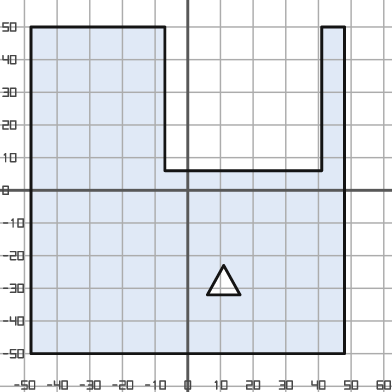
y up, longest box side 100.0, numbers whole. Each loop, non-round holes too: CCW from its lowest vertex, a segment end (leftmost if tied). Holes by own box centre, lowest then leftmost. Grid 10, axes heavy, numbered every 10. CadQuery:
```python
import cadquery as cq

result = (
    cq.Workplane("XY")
    .moveTo(-48.0, -50.0)
    .lineTo(48.0, -50.0)
    .lineTo(48.0, 50.0)
    .lineTo(41.0, 50.0)
    .lineTo(41.0, 6.0)
    .lineTo(-7.0, 6.0)
    .lineTo(-7.0, 50.0)
    .lineTo(-48.0, 50.0)
    .close()
    .moveTo(6.0, -32.0)
    .lineTo(16.0, -32.0)
    .lineTo(11.0, -23.0)
    .close()
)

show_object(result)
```